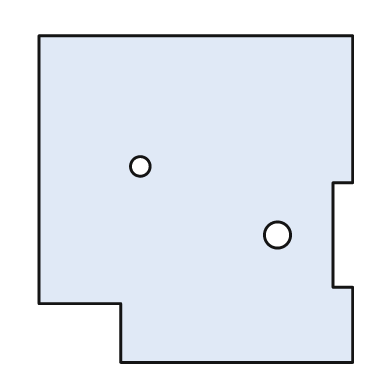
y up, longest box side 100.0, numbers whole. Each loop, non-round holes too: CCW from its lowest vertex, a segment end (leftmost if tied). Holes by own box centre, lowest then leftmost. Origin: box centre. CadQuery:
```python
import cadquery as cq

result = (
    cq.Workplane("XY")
    .moveTo(-23.0, -50.0)
    .lineTo(48.0, -50.0)
    .lineTo(48.0, -27.0)
    .lineTo(42.0, -27.0)
    .lineTo(42.0, 5.0)
    .lineTo(48.0, 5.0)
    .lineTo(48.0, 50.0)
    .lineTo(-48.0, 50.0)
    .lineTo(-48.0, -32.0)
    .lineTo(-23.0, -32.0)
    .close()
    .moveTo(25.0, -11.0)
    .circle(4.0)
    .moveTo(-17.0, 10.0)
    .circle(3.0)
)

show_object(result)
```